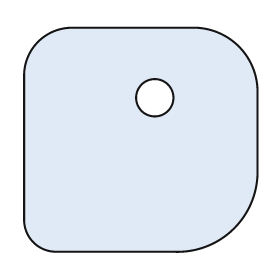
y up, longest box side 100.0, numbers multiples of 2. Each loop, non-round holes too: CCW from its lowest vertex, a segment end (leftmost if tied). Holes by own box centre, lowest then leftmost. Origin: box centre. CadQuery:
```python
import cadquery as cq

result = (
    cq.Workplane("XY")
    .moveTo(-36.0, -48.0)
    .lineTo(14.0, -48.0)
    .threePointArc((40.0, -38.0), (50.0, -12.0))
    .lineTo(50.0, 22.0)
    .threePointArc((42.0, 40.0), (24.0, 48.0))
    .lineTo(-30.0, 48.0)
    .threePointArc((-44.0, 42.0), (-50.0, 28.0))
    .lineTo(-50.0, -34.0)
    .threePointArc((-46.0, -44.0), (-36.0, -48.0))
    .close()
    .moveTo(6.0, 18.0)
    .circle(8.0)
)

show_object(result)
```